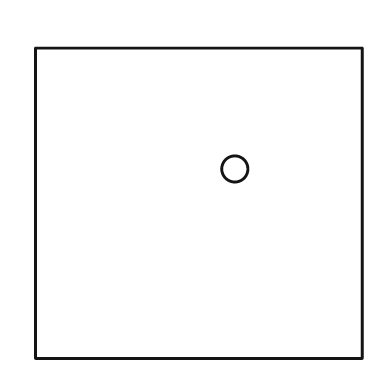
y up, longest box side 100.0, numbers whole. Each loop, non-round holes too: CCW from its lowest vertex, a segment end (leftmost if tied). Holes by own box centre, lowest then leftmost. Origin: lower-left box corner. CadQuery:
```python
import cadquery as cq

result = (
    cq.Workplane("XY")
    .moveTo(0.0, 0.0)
    .lineTo(100.0, 0.0)
    .lineTo(100.0, 95.0)
    .lineTo(0.0, 95.0)
    .close()
    .moveTo(61.0, 58.0)
    .circle(4.0)
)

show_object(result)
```